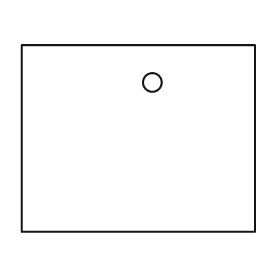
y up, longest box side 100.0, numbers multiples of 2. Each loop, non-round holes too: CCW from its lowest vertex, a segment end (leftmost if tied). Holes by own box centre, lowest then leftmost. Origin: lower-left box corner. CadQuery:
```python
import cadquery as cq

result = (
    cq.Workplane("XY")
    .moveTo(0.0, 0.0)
    .lineTo(100.0, 0.0)
    .lineTo(100.0, 80.0)
    .lineTo(0.0, 80.0)
    .close()
    .moveTo(56.0, 64.0)
    .circle(4.0)
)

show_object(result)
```